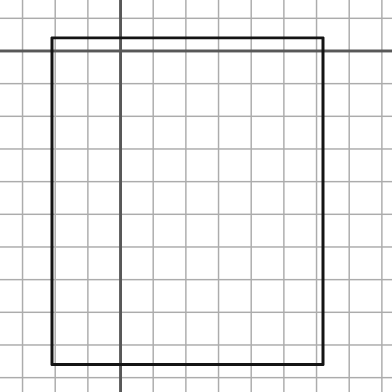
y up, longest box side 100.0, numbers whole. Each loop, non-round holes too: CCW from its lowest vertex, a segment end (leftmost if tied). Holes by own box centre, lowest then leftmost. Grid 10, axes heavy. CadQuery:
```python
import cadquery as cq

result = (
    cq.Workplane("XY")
    .moveTo(-21.0, -96.0)
    .lineTo(62.0, -96.0)
    .lineTo(62.0, 4.0)
    .lineTo(-21.0, 4.0)
    .close()
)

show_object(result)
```